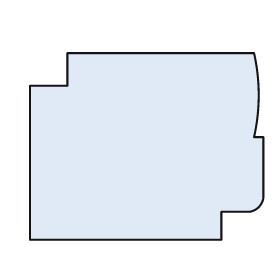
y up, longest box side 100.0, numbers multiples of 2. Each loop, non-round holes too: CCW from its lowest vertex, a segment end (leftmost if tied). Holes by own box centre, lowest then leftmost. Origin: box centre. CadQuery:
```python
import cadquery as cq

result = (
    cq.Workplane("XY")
    .moveTo(-50.0, -40.0)
    .lineTo(32.0, -40.0)
    .lineTo(32.0, -28.0)
    .lineTo(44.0, -28.0)
    .threePointArc((48.0, -26.0), (50.0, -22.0))
    .lineTo(50.0, 4.0)
    .lineTo(46.0, 4.0)
    .threePointArc((48.0, 22.0), (46.0, 40.0))
    .lineTo(-34.0, 40.0)
    .lineTo(-34.0, 26.0)
    .lineTo(-50.0, 26.0)
    .close()
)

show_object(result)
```